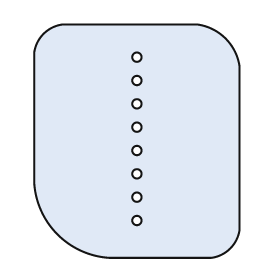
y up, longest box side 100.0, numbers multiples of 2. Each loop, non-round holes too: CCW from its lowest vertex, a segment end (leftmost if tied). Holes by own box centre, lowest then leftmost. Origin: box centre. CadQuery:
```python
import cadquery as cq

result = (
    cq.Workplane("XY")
    .moveTo(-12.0, -50.0)
    .lineTo(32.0, -50.0)
    .threePointArc((40.0, -46.0), (44.0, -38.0))
    .lineTo(44.0, 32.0)
    .threePointArc((38.0, 44.0), (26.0, 50.0))
    .lineTo(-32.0, 50.0)
    .threePointArc((-40.0, 46.0), (-44.0, 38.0))
    .lineTo(-44.0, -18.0)
    .threePointArc((-34.0, -40.0), (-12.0, -50.0))
    .close()
    .moveTo(0.0, -34.0)
    .circle(2.0)
    .moveTo(0.0, -24.0)
    .circle(2.0)
    .moveTo(0.0, -14.0)
    .circle(2.0)
    .moveTo(0.0, -4.0)
    .circle(2.0)
    .moveTo(0.0, 6.0)
    .circle(2.0)
    .moveTo(0.0, 16.0)
    .circle(2.0)
    .moveTo(0.0, 26.0)
    .circle(2.0)
    .moveTo(0.0, 36.0)
    .circle(2.0)
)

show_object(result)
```